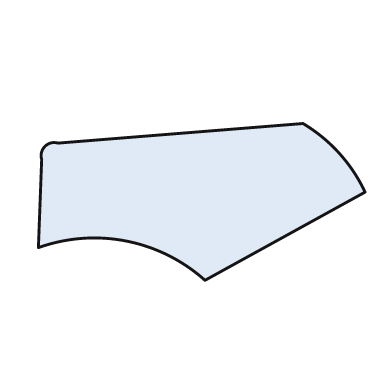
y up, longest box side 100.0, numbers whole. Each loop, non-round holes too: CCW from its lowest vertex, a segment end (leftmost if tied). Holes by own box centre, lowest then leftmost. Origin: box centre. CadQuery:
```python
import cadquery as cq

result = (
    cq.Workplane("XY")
    .moveTo(1.0, -24.0)
    .lineTo(50.0, 3.0)
    .threePointArc((42.0, 15.0), (31.0, 24.0))
    .lineTo(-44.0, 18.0)
    .threePointArc((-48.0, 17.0), (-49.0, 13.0))
    .lineTo(-50.0, -14.0)
    .threePointArc((-23.0, -12.0), (1.0, -24.0))
    .close()
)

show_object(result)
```